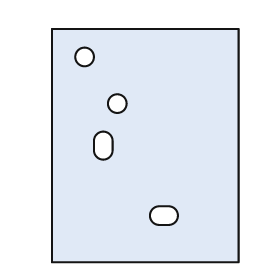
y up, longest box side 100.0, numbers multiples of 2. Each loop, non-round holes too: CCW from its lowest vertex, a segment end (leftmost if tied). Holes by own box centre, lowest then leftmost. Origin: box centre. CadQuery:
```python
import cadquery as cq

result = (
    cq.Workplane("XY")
    .moveTo(-40.0, -50.0)
    .lineTo(40.0, -50.0)
    .lineTo(40.0, 50.0)
    .lineTo(-40.0, 50.0)
    .close()
    .moveTo(6.0, -34.0)
    .lineTo(10.0, -34.0)
    .threePointArc((14.0, -30.0), (10.0, -26.0))
    .lineTo(6.0, -26.0)
    .threePointArc((2.0, -30.0), (6.0, -34.0))
    .close()
    .moveTo(-22.0, -2.0)
    .threePointArc((-18.0, -6.0), (-14.0, -2.0))
    .lineTo(-14.0, 2.0)
    .threePointArc((-18.0, 6.0), (-22.0, 2.0))
    .close()
    .moveTo(-12.0, 18.0)
    .circle(4.0)
    .moveTo(-26.0, 38.0)
    .circle(4.0)
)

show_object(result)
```